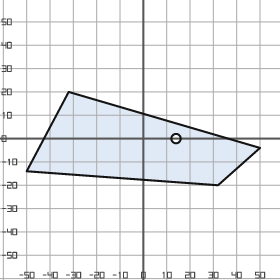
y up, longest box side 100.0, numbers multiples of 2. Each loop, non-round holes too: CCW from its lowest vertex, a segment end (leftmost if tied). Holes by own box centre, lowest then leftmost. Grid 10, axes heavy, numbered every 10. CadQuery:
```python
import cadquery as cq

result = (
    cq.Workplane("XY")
    .moveTo(32.0, -20.0)
    .lineTo(50.0, -4.0)
    .lineTo(-32.0, 20.0)
    .lineTo(-50.0, -14.0)
    .close()
    .moveTo(14.0, 0.0)
    .circle(2.0)
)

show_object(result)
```